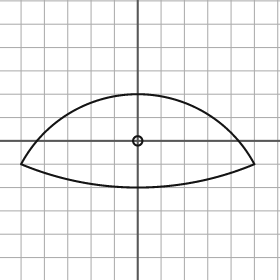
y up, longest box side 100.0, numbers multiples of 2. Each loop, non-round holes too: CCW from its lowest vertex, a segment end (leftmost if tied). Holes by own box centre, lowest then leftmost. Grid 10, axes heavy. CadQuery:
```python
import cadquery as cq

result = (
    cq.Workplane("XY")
    .moveTo(-50.0, -10.0)
    .threePointArc((0.0, -20.0), (50.0, -10.0))
    .threePointArc((0.0, 20.0), (-50.0, -10.0))
    .close()
    .moveTo(0.0, 0.0)
    .circle(2.0)
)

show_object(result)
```